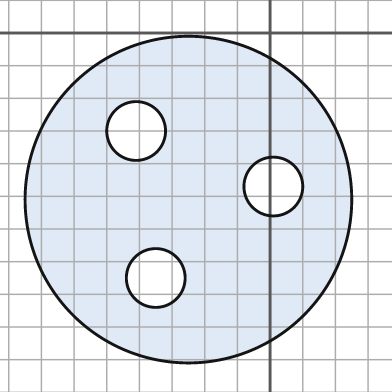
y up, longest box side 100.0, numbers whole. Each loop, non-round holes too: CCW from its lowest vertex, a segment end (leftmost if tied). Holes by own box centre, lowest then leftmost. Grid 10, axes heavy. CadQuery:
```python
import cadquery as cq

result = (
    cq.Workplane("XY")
    .moveTo(-25.0, -51.0)
    .circle(50.0)
    .moveTo(-35.0, -75.0)
    .circle(9.0)
    .moveTo(1.0, -47.0)
    .circle(9.0)
    .moveTo(-41.0, -30.0)
    .circle(9.0)
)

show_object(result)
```